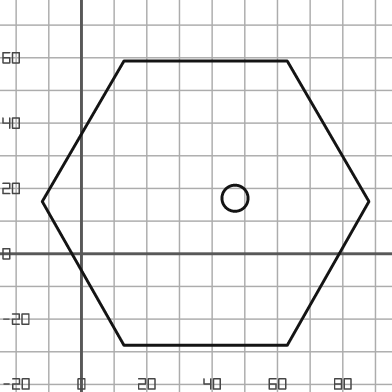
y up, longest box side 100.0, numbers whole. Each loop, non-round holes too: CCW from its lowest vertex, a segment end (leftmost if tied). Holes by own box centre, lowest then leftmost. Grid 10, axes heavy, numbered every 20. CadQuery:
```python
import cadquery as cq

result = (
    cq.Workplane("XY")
    .moveTo(13.0, -28.0)
    .lineTo(63.0, -28.0)
    .lineTo(88.0, 16.0)
    .lineTo(63.0, 59.0)
    .lineTo(13.0, 59.0)
    .lineTo(-12.0, 16.0)
    .close()
    .moveTo(47.0, 17.0)
    .circle(4.0)
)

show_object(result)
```